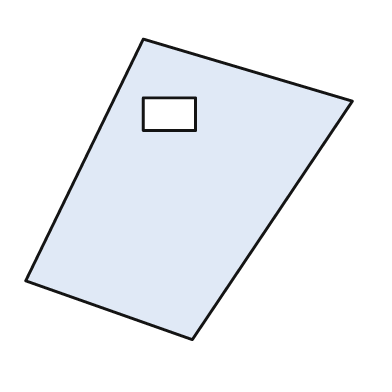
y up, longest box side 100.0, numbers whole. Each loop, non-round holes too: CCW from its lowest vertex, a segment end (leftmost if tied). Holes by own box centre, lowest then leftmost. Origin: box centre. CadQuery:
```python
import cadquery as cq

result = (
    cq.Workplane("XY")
    .moveTo(1.0, -46.0)
    .lineTo(50.0, 27.0)
    .lineTo(-14.0, 46.0)
    .lineTo(-50.0, -28.0)
    .close()
    .moveTo(-14.0, 18.0)
    .lineTo(2.0, 18.0)
    .lineTo(2.0, 28.0)
    .lineTo(-14.0, 28.0)
    .close()
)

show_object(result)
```